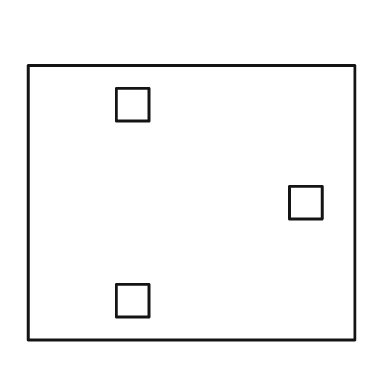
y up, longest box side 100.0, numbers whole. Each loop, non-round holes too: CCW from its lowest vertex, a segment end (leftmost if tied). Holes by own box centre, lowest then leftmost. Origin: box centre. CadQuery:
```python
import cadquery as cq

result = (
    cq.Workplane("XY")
    .moveTo(-50.0, -42.0)
    .lineTo(50.0, -42.0)
    .lineTo(50.0, 42.0)
    .lineTo(-50.0, 42.0)
    .close()
    .moveTo(-23.0, -35.0)
    .lineTo(-13.0, -35.0)
    .lineTo(-13.0, -25.0)
    .lineTo(-23.0, -25.0)
    .close()
    .moveTo(30.0, -5.0)
    .lineTo(40.0, -5.0)
    .lineTo(40.0, 5.0)
    .lineTo(30.0, 5.0)
    .close()
    .moveTo(-23.0, 25.0)
    .lineTo(-13.0, 25.0)
    .lineTo(-13.0, 35.0)
    .lineTo(-23.0, 35.0)
    .close()
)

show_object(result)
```